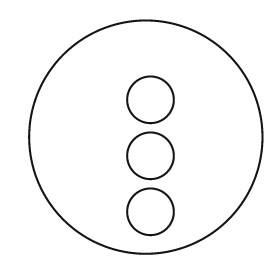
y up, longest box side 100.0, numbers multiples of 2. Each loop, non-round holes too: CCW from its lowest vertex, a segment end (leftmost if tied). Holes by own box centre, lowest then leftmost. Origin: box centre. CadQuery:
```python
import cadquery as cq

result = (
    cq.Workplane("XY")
    .moveTo(0.0, 0.0)
    .circle(50.0)
    .moveTo(2.0, -32.0)
    .circle(10.0)
    .moveTo(2.0, -8.0)
    .circle(10.0)
    .moveTo(2.0, 16.0)
    .circle(10.0)
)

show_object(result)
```